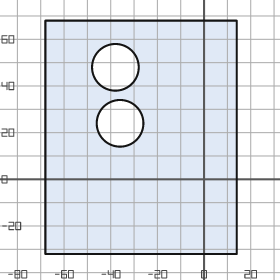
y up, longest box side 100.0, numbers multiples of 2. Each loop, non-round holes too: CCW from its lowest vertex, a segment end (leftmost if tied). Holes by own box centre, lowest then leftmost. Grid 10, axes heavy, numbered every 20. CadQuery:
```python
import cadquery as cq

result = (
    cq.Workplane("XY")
    .moveTo(-68.0, -32.0)
    .lineTo(14.0, -32.0)
    .lineTo(14.0, 68.0)
    .lineTo(-68.0, 68.0)
    .close()
    .moveTo(-36.0, 24.0)
    .circle(10.0)
    .moveTo(-38.0, 48.0)
    .circle(10.0)
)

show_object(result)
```